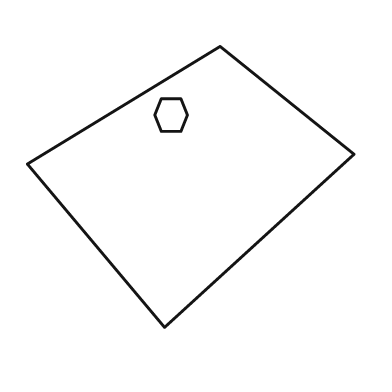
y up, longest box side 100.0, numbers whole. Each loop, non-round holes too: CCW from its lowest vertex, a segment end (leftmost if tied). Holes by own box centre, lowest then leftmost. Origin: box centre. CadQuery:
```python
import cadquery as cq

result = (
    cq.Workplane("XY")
    .moveTo(-8.0, -43.0)
    .lineTo(50.0, 10.0)
    .lineTo(9.0, 43.0)
    .lineTo(-50.0, 7.0)
    .close()
    .moveTo(-9.0, 17.0)
    .lineTo(-3.0, 17.0)
    .lineTo(-1.0, 22.0)
    .lineTo(-3.0, 27.0)
    .lineTo(-9.0, 27.0)
    .lineTo(-11.0, 22.0)
    .close()
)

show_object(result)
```